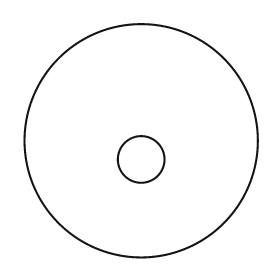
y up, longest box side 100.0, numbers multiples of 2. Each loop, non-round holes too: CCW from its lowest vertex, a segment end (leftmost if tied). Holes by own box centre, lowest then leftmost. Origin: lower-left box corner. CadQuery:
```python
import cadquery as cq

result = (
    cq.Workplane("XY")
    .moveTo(50.0, 50.0)
    .circle(50.0)
    .moveTo(50.0, 42.0)
    .circle(10.0)
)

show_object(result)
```